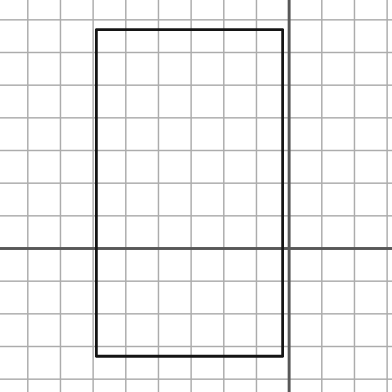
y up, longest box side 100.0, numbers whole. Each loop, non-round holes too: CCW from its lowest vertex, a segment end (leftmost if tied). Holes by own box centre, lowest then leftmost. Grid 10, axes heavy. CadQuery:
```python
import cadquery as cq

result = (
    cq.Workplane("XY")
    .moveTo(-59.0, -33.0)
    .lineTo(-2.0, -33.0)
    .lineTo(-2.0, 67.0)
    .lineTo(-59.0, 67.0)
    .close()
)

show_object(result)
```